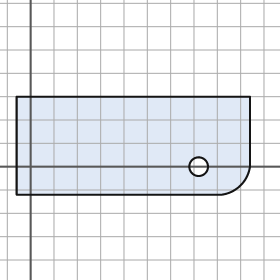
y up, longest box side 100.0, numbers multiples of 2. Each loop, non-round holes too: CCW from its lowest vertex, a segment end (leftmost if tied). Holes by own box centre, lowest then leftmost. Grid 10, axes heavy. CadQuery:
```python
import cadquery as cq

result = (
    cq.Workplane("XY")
    .moveTo(-6.0, -12.0)
    .lineTo(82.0, -12.0)
    .threePointArc((90.0, -8.0), (94.0, 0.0))
    .lineTo(94.0, 30.0)
    .lineTo(-6.0, 30.0)
    .close()
    .moveTo(72.0, 0.0)
    .circle(4.0)
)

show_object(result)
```